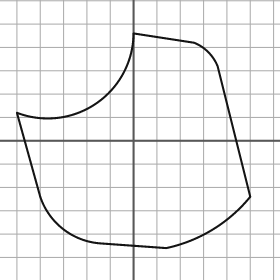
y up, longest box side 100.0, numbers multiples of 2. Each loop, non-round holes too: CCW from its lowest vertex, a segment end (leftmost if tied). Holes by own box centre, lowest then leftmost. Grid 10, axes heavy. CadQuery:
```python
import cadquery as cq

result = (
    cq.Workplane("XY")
    .moveTo(14.0, -46.0)
    .threePointArc((34.0, -38.0), (50.0, -24.0))
    .lineTo(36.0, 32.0)
    .threePointArc((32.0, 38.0), (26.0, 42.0))
    .lineTo(0.0, 46.0)
    .threePointArc((-16.0, 16.0), (-50.0, 12.0))
    .lineTo(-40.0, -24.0)
    .threePointArc((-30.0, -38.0), (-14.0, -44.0))
    .close()
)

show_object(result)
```